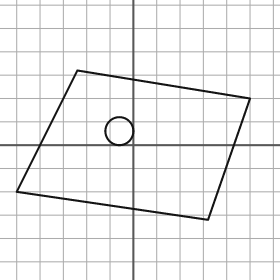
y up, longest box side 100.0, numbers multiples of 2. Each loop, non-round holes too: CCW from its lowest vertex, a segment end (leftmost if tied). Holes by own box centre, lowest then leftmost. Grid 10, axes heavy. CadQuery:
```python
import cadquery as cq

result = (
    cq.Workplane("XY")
    .moveTo(32.0, -32.0)
    .lineTo(50.0, 20.0)
    .lineTo(-24.0, 32.0)
    .lineTo(-50.0, -20.0)
    .close()
    .moveTo(-6.0, 6.0)
    .circle(6.0)
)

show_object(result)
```